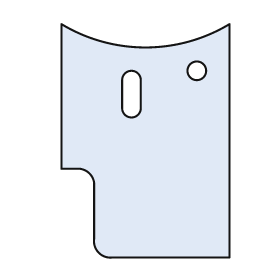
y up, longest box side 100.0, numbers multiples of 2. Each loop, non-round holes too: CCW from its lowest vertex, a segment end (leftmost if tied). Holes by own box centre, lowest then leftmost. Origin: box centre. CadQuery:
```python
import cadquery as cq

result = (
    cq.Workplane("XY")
    .moveTo(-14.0, -50.0)
    .lineTo(36.0, -50.0)
    .lineTo(36.0, 50.0)
    .threePointArc((0.0, 40.0), (-36.0, 50.0))
    .lineTo(-36.0, -12.0)
    .lineTo(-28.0, -12.0)
    .threePointArc((-24.0, -14.0), (-22.0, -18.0))
    .lineTo(-22.0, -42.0)
    .threePointArc((-20.0, -48.0), (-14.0, -50.0))
    .close()
    .moveTo(-10.0, 14.0)
    .threePointArc((-6.0, 10.0), (-2.0, 14.0))
    .lineTo(-2.0, 26.0)
    .threePointArc((-6.0, 30.0), (-10.0, 26.0))
    .close()
    .moveTo(22.0, 30.0)
    .circle(4.0)
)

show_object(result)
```